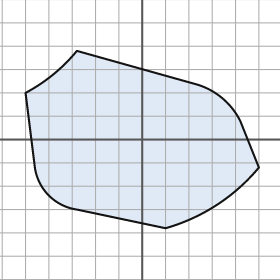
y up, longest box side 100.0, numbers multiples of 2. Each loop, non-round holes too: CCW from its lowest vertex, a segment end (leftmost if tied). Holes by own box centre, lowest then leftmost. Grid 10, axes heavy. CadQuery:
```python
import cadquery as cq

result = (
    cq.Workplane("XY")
    .moveTo(10.0, -38.0)
    .threePointArc((32.0, -28.0), (50.0, -12.0))
    .lineTo(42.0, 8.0)
    .threePointArc((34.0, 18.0), (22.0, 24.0))
    .lineTo(-28.0, 38.0)
    .threePointArc((-38.0, 28.0), (-50.0, 20.0))
    .lineTo(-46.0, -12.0)
    .threePointArc((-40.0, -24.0), (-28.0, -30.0))
    .close()
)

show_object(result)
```